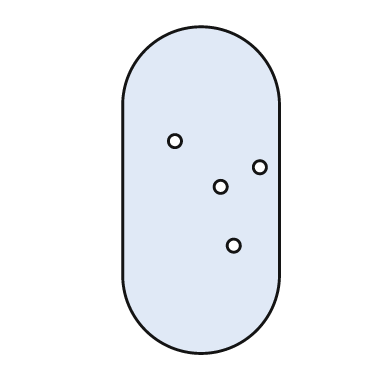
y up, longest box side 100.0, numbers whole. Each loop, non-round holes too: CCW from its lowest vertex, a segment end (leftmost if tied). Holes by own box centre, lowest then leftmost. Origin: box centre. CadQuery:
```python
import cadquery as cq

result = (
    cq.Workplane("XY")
    .moveTo(-24.0, -26.0)
    .threePointArc((0.0, -50.0), (24.0, -26.0))
    .lineTo(24.0, 26.0)
    .threePointArc((0.0, 50.0), (-24.0, 26.0))
    .close()
    .moveTo(10.0, -17.0)
    .circle(2.0)
    .moveTo(6.0, 1.0)
    .circle(2.0)
    .moveTo(18.0, 7.0)
    .circle(2.0)
    .moveTo(-8.0, 15.0)
    .circle(2.0)
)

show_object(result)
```